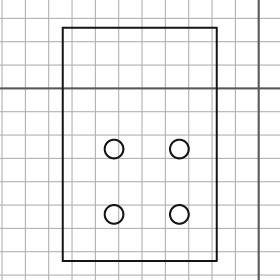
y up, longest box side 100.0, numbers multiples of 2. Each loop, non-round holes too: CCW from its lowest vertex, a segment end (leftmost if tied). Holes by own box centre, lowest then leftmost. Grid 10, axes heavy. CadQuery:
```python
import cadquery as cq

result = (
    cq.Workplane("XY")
    .moveTo(-84.0, -74.0)
    .lineTo(-18.0, -74.0)
    .lineTo(-18.0, 26.0)
    .lineTo(-84.0, 26.0)
    .close()
    .moveTo(-62.0, -54.0)
    .circle(4.0)
    .moveTo(-34.0, -54.0)
    .circle(4.0)
    .moveTo(-62.0, -26.0)
    .circle(4.0)
    .moveTo(-34.0, -26.0)
    .circle(4.0)
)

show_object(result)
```